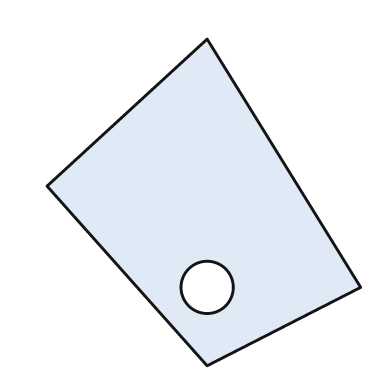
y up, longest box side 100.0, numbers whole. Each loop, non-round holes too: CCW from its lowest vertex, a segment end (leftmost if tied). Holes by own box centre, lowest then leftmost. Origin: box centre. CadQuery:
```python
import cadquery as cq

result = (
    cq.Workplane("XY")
    .moveTo(1.0, -50.0)
    .lineTo(48.0, -26.0)
    .lineTo(1.0, 50.0)
    .lineTo(-48.0, 5.0)
    .close()
    .moveTo(1.0, -26.0)
    .circle(8.0)
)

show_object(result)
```